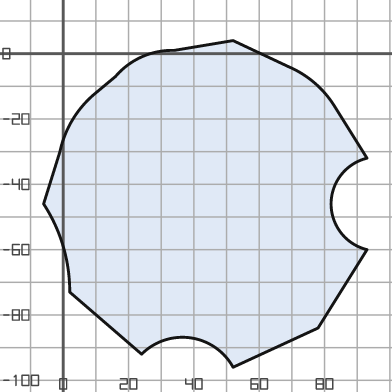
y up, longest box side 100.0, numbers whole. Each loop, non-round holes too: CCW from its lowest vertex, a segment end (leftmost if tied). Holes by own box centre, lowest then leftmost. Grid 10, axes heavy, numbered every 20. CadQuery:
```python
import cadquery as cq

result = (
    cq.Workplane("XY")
    .moveTo(52.0, -96.0)
    .lineTo(78.0, -84.0)
    .lineTo(93.0, -60.0)
    .threePointArc((82.0, -46.0), (93.0, -32.0))
    .lineTo(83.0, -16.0)
    .threePointArc((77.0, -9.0), (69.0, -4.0))
    .lineTo(52.0, 4.0)
    .lineTo(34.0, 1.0)
    .threePointArc((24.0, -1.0), (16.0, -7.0))
    .lineTo(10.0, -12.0)
    .threePointArc((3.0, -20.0), (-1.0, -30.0))
    .lineTo(-6.0, -46.0)
    .threePointArc((0.0, -59.0), (2.0, -73.0))
    .lineTo(24.0, -92.0)
    .threePointArc((39.0, -87.0), (52.0, -96.0))
    .close()
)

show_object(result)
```